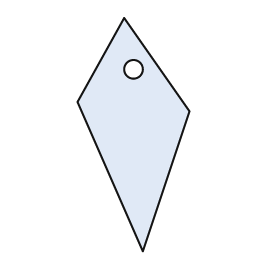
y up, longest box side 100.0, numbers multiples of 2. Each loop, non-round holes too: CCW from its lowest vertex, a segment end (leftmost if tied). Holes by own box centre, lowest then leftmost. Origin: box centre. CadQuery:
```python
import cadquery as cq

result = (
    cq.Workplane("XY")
    .moveTo(4.0, -50.0)
    .lineTo(24.0, 10.0)
    .lineTo(-4.0, 50.0)
    .lineTo(-24.0, 14.0)
    .close()
    .moveTo(0.0, 28.0)
    .circle(4.0)
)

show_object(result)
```